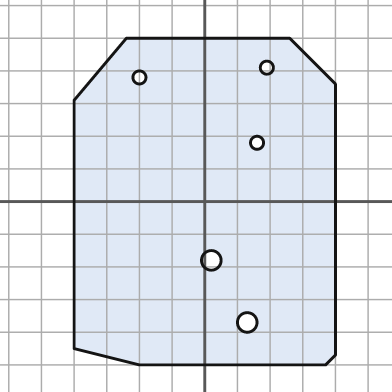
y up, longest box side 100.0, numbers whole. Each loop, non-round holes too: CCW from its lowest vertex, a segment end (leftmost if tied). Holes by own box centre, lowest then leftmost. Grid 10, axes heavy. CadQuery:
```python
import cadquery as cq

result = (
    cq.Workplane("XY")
    .moveTo(-20.0, -50.0)
    .lineTo(37.0, -50.0)
    .lineTo(40.0, -47.0)
    .lineTo(40.0, 36.0)
    .lineTo(26.0, 50.0)
    .lineTo(-24.0, 50.0)
    .lineTo(-40.0, 31.0)
    .lineTo(-40.0, -45.0)
    .close()
    .moveTo(13.0, -37.0)
    .circle(3.0)
    .moveTo(2.0, -18.0)
    .circle(3.0)
    .moveTo(16.0, 18.0)
    .circle(2.0)
    .moveTo(-20.0, 38.0)
    .circle(2.0)
    .moveTo(19.0, 41.0)
    .circle(2.0)
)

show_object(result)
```